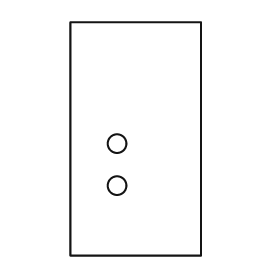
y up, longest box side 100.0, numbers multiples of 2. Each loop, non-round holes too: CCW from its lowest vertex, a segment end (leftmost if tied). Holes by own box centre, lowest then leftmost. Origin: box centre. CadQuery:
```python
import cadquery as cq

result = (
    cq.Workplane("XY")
    .moveTo(-28.0, -50.0)
    .lineTo(28.0, -50.0)
    .lineTo(28.0, 50.0)
    .lineTo(-28.0, 50.0)
    .close()
    .moveTo(-8.0, -20.0)
    .circle(4.0)
    .moveTo(-8.0, -2.0)
    .circle(4.0)
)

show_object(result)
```